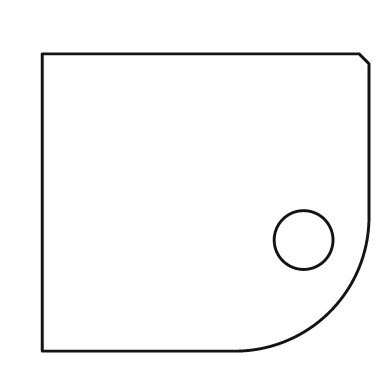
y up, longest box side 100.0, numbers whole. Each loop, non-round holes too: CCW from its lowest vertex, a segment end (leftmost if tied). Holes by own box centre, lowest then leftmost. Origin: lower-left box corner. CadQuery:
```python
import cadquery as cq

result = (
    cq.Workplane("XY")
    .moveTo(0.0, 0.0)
    .lineTo(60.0, 0.0)
    .threePointArc((88.0, 12.0), (100.0, 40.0))
    .lineTo(100.0, 88.0)
    .lineTo(97.0, 91.0)
    .lineTo(0.0, 91.0)
    .close()
    .moveTo(80.0, 34.0)
    .circle(9.0)
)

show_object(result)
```